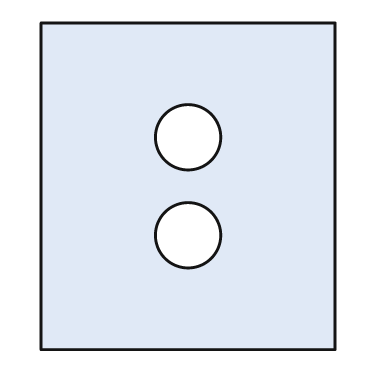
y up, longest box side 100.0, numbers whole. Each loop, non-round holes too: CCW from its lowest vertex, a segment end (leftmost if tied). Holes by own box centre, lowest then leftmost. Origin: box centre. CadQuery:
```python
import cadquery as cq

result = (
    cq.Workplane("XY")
    .moveTo(-45.0, -50.0)
    .lineTo(45.0, -50.0)
    .lineTo(45.0, 50.0)
    .lineTo(-45.0, 50.0)
    .close()
    .moveTo(0.0, -15.0)
    .circle(10.0)
    .moveTo(0.0, 15.0)
    .circle(10.0)
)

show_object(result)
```